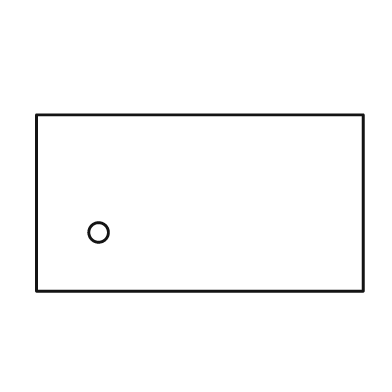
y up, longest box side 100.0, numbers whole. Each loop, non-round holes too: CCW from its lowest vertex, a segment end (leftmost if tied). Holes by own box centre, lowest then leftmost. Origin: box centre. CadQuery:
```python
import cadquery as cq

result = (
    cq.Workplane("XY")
    .moveTo(-50.0, -27.0)
    .lineTo(50.0, -27.0)
    .lineTo(50.0, 27.0)
    .lineTo(-50.0, 27.0)
    .close()
    .moveTo(-31.0, -9.0)
    .circle(3.0)
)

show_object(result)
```